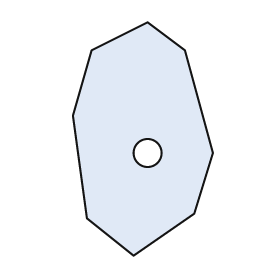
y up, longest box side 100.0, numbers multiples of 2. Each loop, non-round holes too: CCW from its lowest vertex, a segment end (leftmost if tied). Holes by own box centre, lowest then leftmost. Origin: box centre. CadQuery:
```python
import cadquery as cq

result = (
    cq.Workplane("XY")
    .moveTo(-4.0, -50.0)
    .lineTo(22.0, -32.0)
    .lineTo(30.0, -6.0)
    .lineTo(18.0, 38.0)
    .lineTo(2.0, 50.0)
    .lineTo(-22.0, 38.0)
    .lineTo(-30.0, 10.0)
    .lineTo(-24.0, -34.0)
    .close()
    .moveTo(2.0, -6.0)
    .circle(6.0)
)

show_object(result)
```